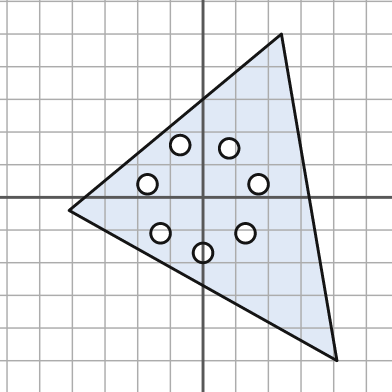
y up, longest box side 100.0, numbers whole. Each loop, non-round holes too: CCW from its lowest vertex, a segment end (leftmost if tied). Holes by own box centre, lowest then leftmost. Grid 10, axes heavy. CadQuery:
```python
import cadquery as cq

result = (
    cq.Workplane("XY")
    .moveTo(41.0, -50.0)
    .lineTo(24.0, 50.0)
    .lineTo(-41.0, -4.0)
    .close()
    .moveTo(0.0, -17.0)
    .circle(3.0)
    .moveTo(-13.0, -11.0)
    .circle(3.0)
    .moveTo(13.0, -11.0)
    .circle(3.0)
    .moveTo(-17.0, 4.0)
    .circle(3.0)
    .moveTo(17.0, 4.0)
    .circle(3.0)
    .moveTo(8.0, 15.0)
    .circle(3.0)
    .moveTo(-7.0, 16.0)
    .circle(3.0)
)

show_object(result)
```